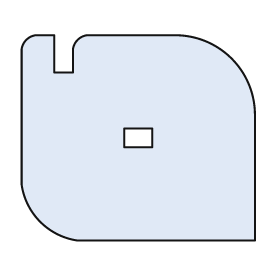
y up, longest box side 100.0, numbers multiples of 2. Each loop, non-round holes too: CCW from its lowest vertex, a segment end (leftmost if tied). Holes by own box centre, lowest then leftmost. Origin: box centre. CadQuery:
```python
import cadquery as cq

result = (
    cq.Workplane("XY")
    .moveTo(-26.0, -44.0)
    .lineTo(50.0, -44.0)
    .lineTo(50.0, 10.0)
    .threePointArc((40.0, 34.0), (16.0, 44.0))
    .lineTo(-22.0, 44.0)
    .threePointArc((-26.0, 42.0), (-28.0, 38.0))
    .lineTo(-28.0, 28.0)
    .lineTo(-36.0, 28.0)
    .lineTo(-36.0, 44.0)
    .lineTo(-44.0, 44.0)
    .threePointArc((-48.0, 42.0), (-50.0, 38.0))
    .lineTo(-50.0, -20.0)
    .threePointArc((-42.0, -36.0), (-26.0, -44.0))
    .close()
    .moveTo(-6.0, -4.0)
    .lineTo(6.0, -4.0)
    .lineTo(6.0, 4.0)
    .lineTo(-6.0, 4.0)
    .close()
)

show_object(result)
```